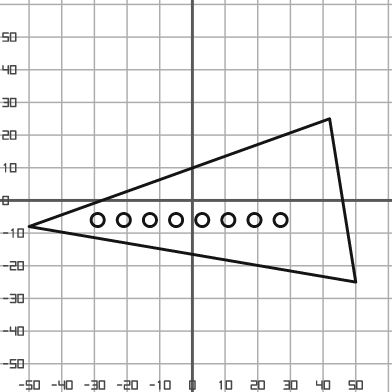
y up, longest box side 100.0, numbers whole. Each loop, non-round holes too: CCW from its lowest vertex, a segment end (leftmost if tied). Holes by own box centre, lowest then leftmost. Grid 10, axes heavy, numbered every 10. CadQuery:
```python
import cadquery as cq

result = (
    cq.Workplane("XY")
    .moveTo(50.0, -25.0)
    .lineTo(42.0, 25.0)
    .lineTo(-50.0, -8.0)
    .close()
    .moveTo(-29.0, -6.0)
    .circle(2.0)
    .moveTo(-21.0, -6.0)
    .circle(2.0)
    .moveTo(-13.0, -6.0)
    .circle(2.0)
    .moveTo(-5.0, -6.0)
    .circle(2.0)
    .moveTo(3.0, -6.0)
    .circle(2.0)
    .moveTo(11.0, -6.0)
    .circle(2.0)
    .moveTo(19.0, -6.0)
    .circle(2.0)
    .moveTo(27.0, -6.0)
    .circle(2.0)
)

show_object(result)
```